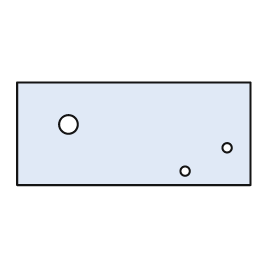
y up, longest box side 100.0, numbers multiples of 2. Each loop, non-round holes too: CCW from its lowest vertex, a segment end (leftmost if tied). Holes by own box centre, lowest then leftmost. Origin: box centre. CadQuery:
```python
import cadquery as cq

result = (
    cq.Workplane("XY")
    .moveTo(-50.0, -22.0)
    .lineTo(50.0, -22.0)
    .lineTo(50.0, 22.0)
    .lineTo(-50.0, 22.0)
    .close()
    .moveTo(22.0, -16.0)
    .circle(2.0)
    .moveTo(40.0, -6.0)
    .circle(2.0)
    .moveTo(-28.0, 4.0)
    .circle(4.0)
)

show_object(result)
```